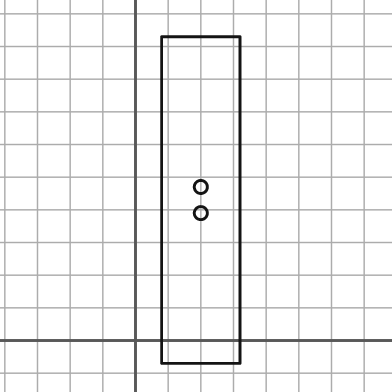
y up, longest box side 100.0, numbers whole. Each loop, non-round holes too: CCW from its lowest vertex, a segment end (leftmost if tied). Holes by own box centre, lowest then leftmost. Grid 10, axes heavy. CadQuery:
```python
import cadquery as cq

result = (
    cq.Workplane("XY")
    .moveTo(8.0, -7.0)
    .lineTo(32.0, -7.0)
    .lineTo(32.0, 93.0)
    .lineTo(8.0, 93.0)
    .close()
    .moveTo(20.0, 39.0)
    .circle(2.0)
    .moveTo(20.0, 47.0)
    .circle(2.0)
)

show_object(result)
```